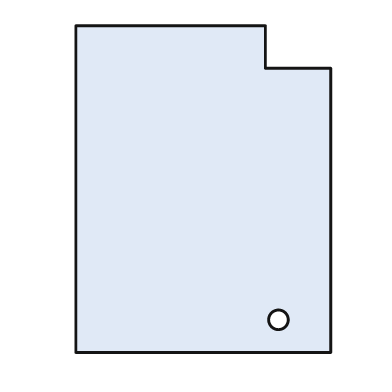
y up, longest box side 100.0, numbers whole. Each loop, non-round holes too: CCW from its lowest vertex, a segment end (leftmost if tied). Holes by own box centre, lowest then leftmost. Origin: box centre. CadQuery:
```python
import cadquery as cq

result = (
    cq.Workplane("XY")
    .moveTo(-39.0, -50.0)
    .lineTo(39.0, -50.0)
    .lineTo(39.0, 37.0)
    .lineTo(19.0, 37.0)
    .lineTo(19.0, 50.0)
    .lineTo(-39.0, 50.0)
    .close()
    .moveTo(23.0, -40.0)
    .circle(3.0)
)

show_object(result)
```